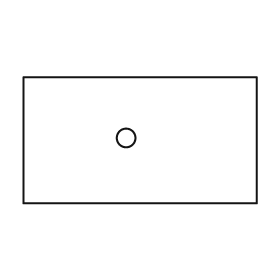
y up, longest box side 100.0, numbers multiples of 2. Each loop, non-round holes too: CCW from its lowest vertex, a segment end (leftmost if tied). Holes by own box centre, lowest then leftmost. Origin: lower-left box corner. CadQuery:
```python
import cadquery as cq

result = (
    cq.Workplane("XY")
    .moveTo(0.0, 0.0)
    .lineTo(100.0, 0.0)
    .lineTo(100.0, 54.0)
    .lineTo(0.0, 54.0)
    .close()
    .moveTo(44.0, 28.0)
    .circle(4.0)
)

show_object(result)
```